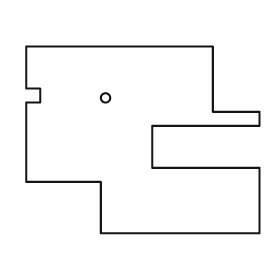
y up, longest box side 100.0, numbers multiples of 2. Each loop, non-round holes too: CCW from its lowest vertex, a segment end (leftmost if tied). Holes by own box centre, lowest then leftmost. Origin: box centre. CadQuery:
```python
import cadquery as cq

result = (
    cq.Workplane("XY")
    .moveTo(-18.0, -40.0)
    .lineTo(50.0, -40.0)
    .lineTo(50.0, -12.0)
    .lineTo(4.0, -12.0)
    .lineTo(4.0, 6.0)
    .lineTo(50.0, 6.0)
    .lineTo(50.0, 12.0)
    .lineTo(30.0, 12.0)
    .lineTo(30.0, 40.0)
    .lineTo(-50.0, 40.0)
    .lineTo(-50.0, 22.0)
    .lineTo(-44.0, 22.0)
    .lineTo(-44.0, 16.0)
    .lineTo(-50.0, 16.0)
    .lineTo(-50.0, -18.0)
    .lineTo(-18.0, -18.0)
    .close()
    .moveTo(-16.0, 18.0)
    .circle(2.0)
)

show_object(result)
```